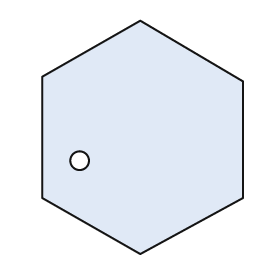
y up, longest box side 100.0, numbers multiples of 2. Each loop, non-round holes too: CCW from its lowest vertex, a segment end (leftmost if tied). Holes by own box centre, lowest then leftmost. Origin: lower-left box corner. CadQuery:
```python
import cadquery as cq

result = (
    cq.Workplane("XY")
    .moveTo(42.0, 0.0)
    .lineTo(86.0, 24.0)
    .lineTo(86.0, 74.0)
    .lineTo(42.0, 100.0)
    .lineTo(0.0, 76.0)
    .lineTo(0.0, 24.0)
    .close()
    .moveTo(16.0, 40.0)
    .circle(4.0)
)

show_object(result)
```